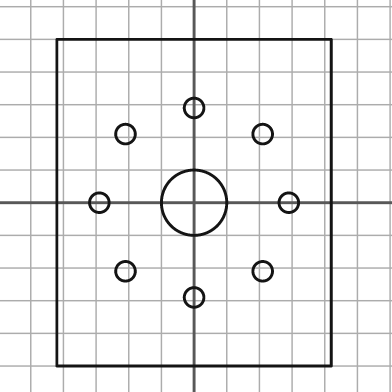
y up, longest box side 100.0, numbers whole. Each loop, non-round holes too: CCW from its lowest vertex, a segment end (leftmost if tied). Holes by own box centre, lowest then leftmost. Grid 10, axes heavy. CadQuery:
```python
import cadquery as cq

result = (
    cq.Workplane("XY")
    .moveTo(-42.0, -50.0)
    .lineTo(42.0, -50.0)
    .lineTo(42.0, 50.0)
    .lineTo(-42.0, 50.0)
    .close()
    .moveTo(0.0, -29.0)
    .circle(3.0)
    .moveTo(-21.0, -21.0)
    .circle(3.0)
    .moveTo(21.0, -21.0)
    .circle(3.0)
    .moveTo(-29.0, 0.0)
    .circle(3.0)
    .moveTo(0.0, 0.0)
    .circle(10.0)
    .moveTo(29.0, 0.0)
    .circle(3.0)
    .moveTo(-21.0, 21.0)
    .circle(3.0)
    .moveTo(21.0, 21.0)
    .circle(3.0)
    .moveTo(0.0, 29.0)
    .circle(3.0)
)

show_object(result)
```